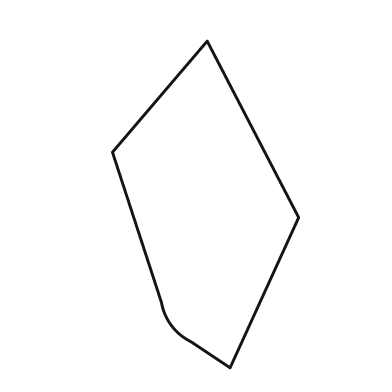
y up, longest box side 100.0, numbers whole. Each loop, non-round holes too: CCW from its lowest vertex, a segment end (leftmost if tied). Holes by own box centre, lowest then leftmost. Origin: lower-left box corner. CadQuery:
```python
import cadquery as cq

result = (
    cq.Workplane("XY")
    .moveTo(36.0, 0.0)
    .lineTo(57.0, 46.0)
    .lineTo(29.0, 100.0)
    .lineTo(0.0, 66.0)
    .lineTo(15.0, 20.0)
    .threePointArc((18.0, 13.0), (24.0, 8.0))
    .close()
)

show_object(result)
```